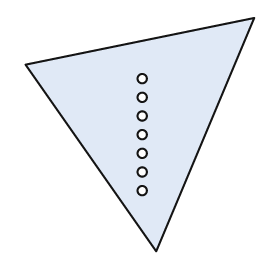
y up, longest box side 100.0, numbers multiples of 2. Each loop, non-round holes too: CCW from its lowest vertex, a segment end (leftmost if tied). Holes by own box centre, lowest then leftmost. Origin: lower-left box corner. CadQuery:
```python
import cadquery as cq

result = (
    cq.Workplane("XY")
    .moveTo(56.0, 0.0)
    .lineTo(98.0, 100.0)
    .lineTo(0.0, 80.0)
    .close()
    .moveTo(50.0, 26.0)
    .circle(2.0)
    .moveTo(50.0, 34.0)
    .circle(2.0)
    .moveTo(50.0, 42.0)
    .circle(2.0)
    .moveTo(50.0, 50.0)
    .circle(2.0)
    .moveTo(50.0, 58.0)
    .circle(2.0)
    .moveTo(50.0, 66.0)
    .circle(2.0)
    .moveTo(50.0, 74.0)
    .circle(2.0)
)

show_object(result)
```